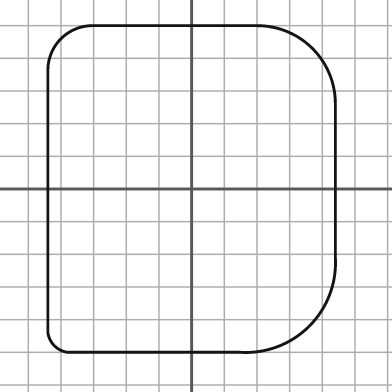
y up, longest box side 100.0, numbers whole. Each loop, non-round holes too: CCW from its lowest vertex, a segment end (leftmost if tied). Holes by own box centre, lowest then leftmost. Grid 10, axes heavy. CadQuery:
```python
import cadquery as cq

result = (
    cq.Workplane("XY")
    .moveTo(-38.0, -50.0)
    .lineTo(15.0, -50.0)
    .threePointArc((36.0, -42.0), (44.0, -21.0))
    .lineTo(44.0, 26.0)
    .threePointArc((37.0, 43.0), (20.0, 50.0))
    .lineTo(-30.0, 50.0)
    .threePointArc((-40.0, 46.0), (-44.0, 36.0))
    .lineTo(-44.0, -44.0)
    .threePointArc((-42.0, -48.0), (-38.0, -50.0))
    .close()
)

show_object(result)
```